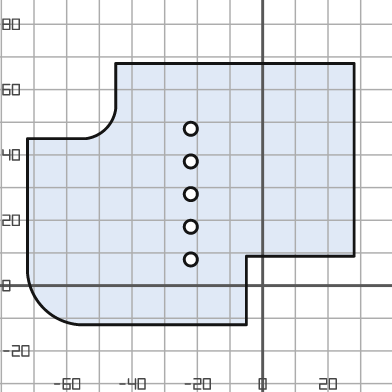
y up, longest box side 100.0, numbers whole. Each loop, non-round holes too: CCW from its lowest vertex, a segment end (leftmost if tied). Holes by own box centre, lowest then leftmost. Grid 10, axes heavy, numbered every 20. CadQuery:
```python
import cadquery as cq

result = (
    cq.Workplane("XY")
    .moveTo(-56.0, -12.0)
    .lineTo(-5.0, -12.0)
    .lineTo(-5.0, 9.0)
    .lineTo(28.0, 9.0)
    .lineTo(28.0, 68.0)
    .lineTo(-45.0, 68.0)
    .lineTo(-45.0, 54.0)
    .threePointArc((-48.0, 48.0), (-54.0, 45.0))
    .lineTo(-72.0, 45.0)
    .lineTo(-72.0, 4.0)
    .threePointArc((-67.0, -7.0), (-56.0, -12.0))
    .close()
    .moveTo(-22.0, 8.0)
    .circle(2.0)
    .moveTo(-22.0, 18.0)
    .circle(2.0)
    .moveTo(-22.0, 28.0)
    .circle(2.0)
    .moveTo(-22.0, 38.0)
    .circle(2.0)
    .moveTo(-22.0, 48.0)
    .circle(2.0)
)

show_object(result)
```